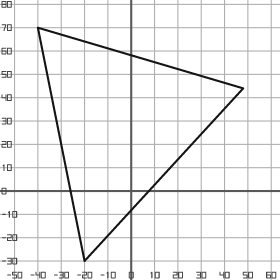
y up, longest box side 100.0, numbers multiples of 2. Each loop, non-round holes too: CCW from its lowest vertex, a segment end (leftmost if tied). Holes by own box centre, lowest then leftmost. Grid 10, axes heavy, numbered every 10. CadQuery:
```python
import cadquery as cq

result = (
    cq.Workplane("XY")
    .moveTo(-20.0, -30.0)
    .lineTo(48.0, 44.0)
    .lineTo(-40.0, 70.0)
    .close()
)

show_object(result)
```